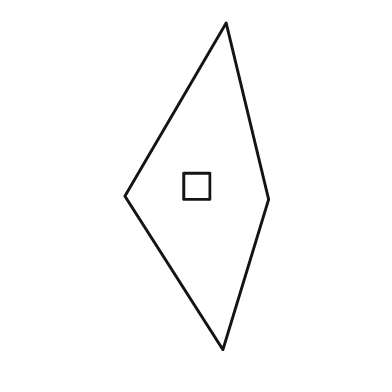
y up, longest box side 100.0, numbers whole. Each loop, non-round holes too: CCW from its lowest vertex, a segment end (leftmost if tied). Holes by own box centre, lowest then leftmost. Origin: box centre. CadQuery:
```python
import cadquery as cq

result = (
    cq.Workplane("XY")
    .moveTo(8.0, -50.0)
    .lineTo(22.0, -4.0)
    .lineTo(9.0, 50.0)
    .lineTo(-22.0, -3.0)
    .close()
    .moveTo(-4.0, -4.0)
    .lineTo(4.0, -4.0)
    .lineTo(4.0, 4.0)
    .lineTo(-4.0, 4.0)
    .close()
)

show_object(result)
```